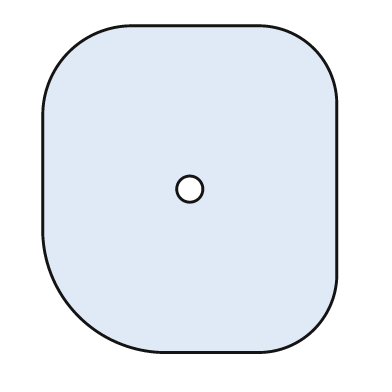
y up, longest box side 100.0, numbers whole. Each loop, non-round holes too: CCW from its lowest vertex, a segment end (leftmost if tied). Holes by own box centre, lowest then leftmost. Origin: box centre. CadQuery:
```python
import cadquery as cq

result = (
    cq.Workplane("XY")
    .moveTo(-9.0, -50.0)
    .lineTo(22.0, -50.0)
    .threePointArc((38.0, -43.0), (45.0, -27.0))
    .lineTo(45.0, 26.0)
    .threePointArc((38.0, 43.0), (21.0, 50.0))
    .lineTo(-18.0, 50.0)
    .threePointArc((-37.0, 42.0), (-45.0, 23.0))
    .lineTo(-45.0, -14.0)
    .threePointArc((-34.0, -39.0), (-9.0, -50.0))
    .close()
    .moveTo(0.0, 0.0)
    .circle(4.0)
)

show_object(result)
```